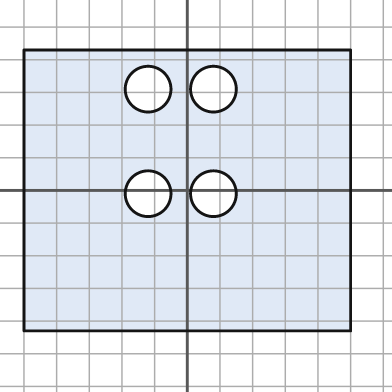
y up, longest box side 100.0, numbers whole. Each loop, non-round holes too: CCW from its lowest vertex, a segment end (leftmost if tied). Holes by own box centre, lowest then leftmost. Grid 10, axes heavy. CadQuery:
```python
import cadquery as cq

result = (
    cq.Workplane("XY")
    .moveTo(-50.0, -43.0)
    .lineTo(50.0, -43.0)
    .lineTo(50.0, 43.0)
    .lineTo(-50.0, 43.0)
    .close()
    .moveTo(-12.0, -1.0)
    .circle(7.0)
    .moveTo(8.0, -1.0)
    .circle(7.0)
    .moveTo(-12.0, 31.0)
    .circle(7.0)
    .moveTo(8.0, 31.0)
    .circle(7.0)
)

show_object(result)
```